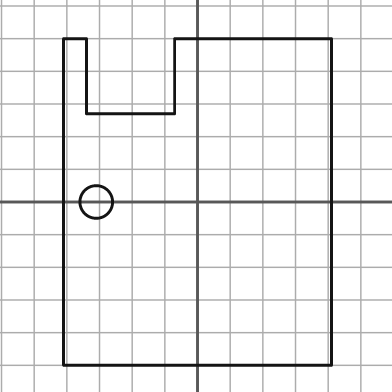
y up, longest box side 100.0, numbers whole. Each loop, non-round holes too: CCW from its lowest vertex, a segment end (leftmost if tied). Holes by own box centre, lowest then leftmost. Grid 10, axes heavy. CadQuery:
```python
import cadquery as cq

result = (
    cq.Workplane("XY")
    .moveTo(-41.0, -50.0)
    .lineTo(41.0, -50.0)
    .lineTo(41.0, 50.0)
    .lineTo(-7.0, 50.0)
    .lineTo(-7.0, 27.0)
    .lineTo(-34.0, 27.0)
    .lineTo(-34.0, 50.0)
    .lineTo(-41.0, 50.0)
    .close()
    .moveTo(-31.0, 0.0)
    .circle(5.0)
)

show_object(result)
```